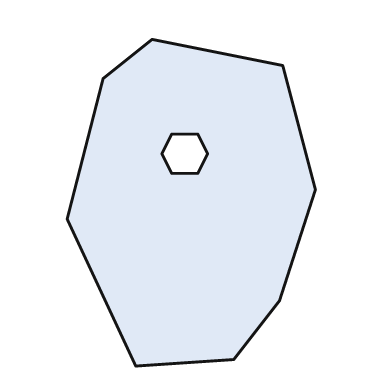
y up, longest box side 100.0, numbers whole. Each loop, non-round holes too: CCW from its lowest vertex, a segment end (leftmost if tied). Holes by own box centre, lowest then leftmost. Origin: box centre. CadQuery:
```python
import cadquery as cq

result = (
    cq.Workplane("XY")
    .moveTo(-17.0, -50.0)
    .lineTo(13.0, -48.0)
    .lineTo(27.0, -30.0)
    .lineTo(38.0, 4.0)
    .lineTo(28.0, 42.0)
    .lineTo(-12.0, 50.0)
    .lineTo(-27.0, 38.0)
    .lineTo(-38.0, -5.0)
    .close()
    .moveTo(-6.0, 9.0)
    .lineTo(2.0, 9.0)
    .lineTo(5.0, 15.0)
    .lineTo(2.0, 21.0)
    .lineTo(-6.0, 21.0)
    .lineTo(-9.0, 15.0)
    .close()
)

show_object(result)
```